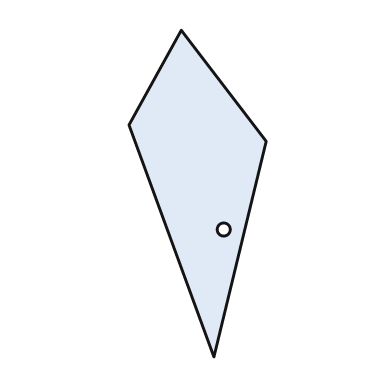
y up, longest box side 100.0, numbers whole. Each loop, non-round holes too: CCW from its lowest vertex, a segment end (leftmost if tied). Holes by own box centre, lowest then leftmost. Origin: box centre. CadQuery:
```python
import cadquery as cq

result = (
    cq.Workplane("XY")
    .moveTo(5.0, -50.0)
    .lineTo(21.0, 16.0)
    .lineTo(-5.0, 50.0)
    .lineTo(-21.0, 21.0)
    .close()
    .moveTo(8.0, -11.0)
    .circle(2.0)
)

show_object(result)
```